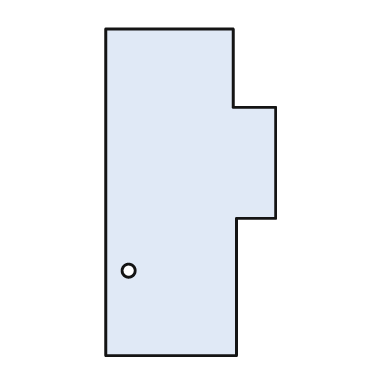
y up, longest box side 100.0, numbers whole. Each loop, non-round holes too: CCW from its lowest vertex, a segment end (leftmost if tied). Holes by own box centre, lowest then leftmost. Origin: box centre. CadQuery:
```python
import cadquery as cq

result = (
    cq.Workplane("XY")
    .moveTo(-26.0, -50.0)
    .lineTo(14.0, -50.0)
    .lineTo(14.0, -8.0)
    .lineTo(26.0, -8.0)
    .lineTo(26.0, 26.0)
    .lineTo(13.0, 26.0)
    .lineTo(13.0, 50.0)
    .lineTo(-26.0, 50.0)
    .close()
    .moveTo(-19.0, -24.0)
    .circle(2.0)
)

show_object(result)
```